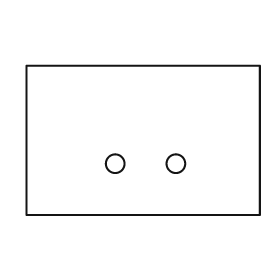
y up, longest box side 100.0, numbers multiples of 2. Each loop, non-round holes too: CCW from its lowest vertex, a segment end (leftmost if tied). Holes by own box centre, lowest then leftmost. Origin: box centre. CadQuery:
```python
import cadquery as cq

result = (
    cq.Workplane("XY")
    .moveTo(-50.0, -32.0)
    .lineTo(50.0, -32.0)
    .lineTo(50.0, 32.0)
    .lineTo(-50.0, 32.0)
    .close()
    .moveTo(-12.0, -10.0)
    .circle(4.0)
    .moveTo(14.0, -10.0)
    .circle(4.0)
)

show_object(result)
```